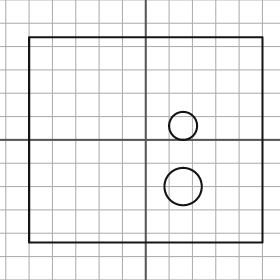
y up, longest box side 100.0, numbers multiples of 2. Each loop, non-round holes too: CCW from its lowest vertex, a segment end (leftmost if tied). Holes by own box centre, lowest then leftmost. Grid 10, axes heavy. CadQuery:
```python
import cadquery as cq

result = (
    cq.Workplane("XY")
    .moveTo(-50.0, -44.0)
    .lineTo(50.0, -44.0)
    .lineTo(50.0, 44.0)
    .lineTo(-50.0, 44.0)
    .close()
    .moveTo(16.0, -20.0)
    .circle(8.0)
    .moveTo(16.0, 6.0)
    .circle(6.0)
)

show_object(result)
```